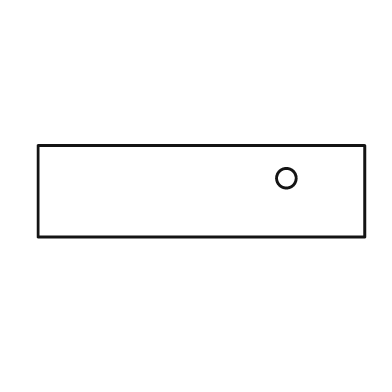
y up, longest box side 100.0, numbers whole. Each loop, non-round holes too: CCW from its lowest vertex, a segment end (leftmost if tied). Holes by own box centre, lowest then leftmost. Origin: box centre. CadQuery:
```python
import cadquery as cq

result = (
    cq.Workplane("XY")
    .moveTo(-50.0, -14.0)
    .lineTo(50.0, -14.0)
    .lineTo(50.0, 14.0)
    .lineTo(-50.0, 14.0)
    .close()
    .moveTo(26.0, 4.0)
    .circle(3.0)
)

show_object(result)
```